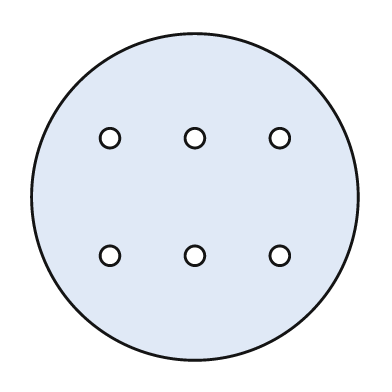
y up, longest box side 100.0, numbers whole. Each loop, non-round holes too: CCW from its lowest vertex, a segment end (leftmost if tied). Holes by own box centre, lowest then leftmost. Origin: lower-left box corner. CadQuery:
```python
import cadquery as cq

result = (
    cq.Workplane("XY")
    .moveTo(50.0, 50.0)
    .circle(50.0)
    .moveTo(24.0, 32.0)
    .circle(3.0)
    .moveTo(50.0, 32.0)
    .circle(3.0)
    .moveTo(76.0, 32.0)
    .circle(3.0)
    .moveTo(24.0, 68.0)
    .circle(3.0)
    .moveTo(50.0, 68.0)
    .circle(3.0)
    .moveTo(76.0, 68.0)
    .circle(3.0)
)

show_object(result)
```